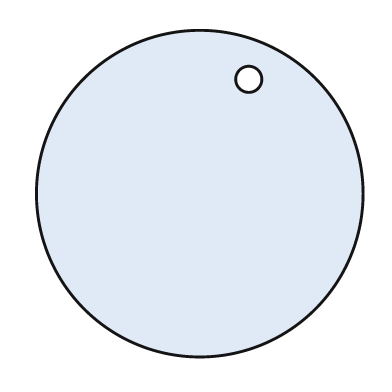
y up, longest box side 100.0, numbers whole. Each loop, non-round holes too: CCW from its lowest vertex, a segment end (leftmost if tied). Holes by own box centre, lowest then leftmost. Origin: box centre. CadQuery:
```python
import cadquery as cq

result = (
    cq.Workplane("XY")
    .moveTo(0.0, 0.0)
    .circle(50.0)
    .moveTo(15.0, 35.0)
    .circle(4.0)
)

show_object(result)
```